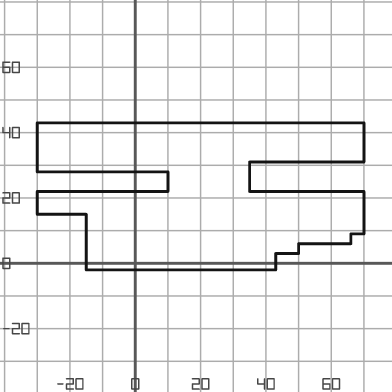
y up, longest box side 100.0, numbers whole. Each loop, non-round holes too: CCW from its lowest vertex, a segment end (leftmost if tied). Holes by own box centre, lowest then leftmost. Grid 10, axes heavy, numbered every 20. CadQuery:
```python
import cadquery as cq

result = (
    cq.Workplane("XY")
    .moveTo(-15.0, -2.0)
    .lineTo(43.0, -2.0)
    .lineTo(43.0, 3.0)
    .lineTo(50.0, 3.0)
    .lineTo(50.0, 6.0)
    .lineTo(66.0, 6.0)
    .lineTo(66.0, 9.0)
    .lineTo(70.0, 9.0)
    .lineTo(70.0, 22.0)
    .lineTo(35.0, 22.0)
    .lineTo(35.0, 31.0)
    .lineTo(70.0, 31.0)
    .lineTo(70.0, 43.0)
    .lineTo(-30.0, 43.0)
    .lineTo(-30.0, 28.0)
    .lineTo(10.0, 28.0)
    .lineTo(10.0, 22.0)
    .lineTo(-30.0, 22.0)
    .lineTo(-30.0, 15.0)
    .lineTo(-15.0, 15.0)
    .close()
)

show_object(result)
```